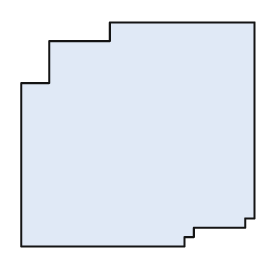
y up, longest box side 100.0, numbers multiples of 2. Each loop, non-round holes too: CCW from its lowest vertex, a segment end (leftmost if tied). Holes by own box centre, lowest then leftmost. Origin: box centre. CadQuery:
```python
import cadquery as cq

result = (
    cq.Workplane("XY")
    .moveTo(-50.0, -48.0)
    .lineTo(20.0, -48.0)
    .lineTo(20.0, -44.0)
    .lineTo(24.0, -44.0)
    .lineTo(24.0, -40.0)
    .lineTo(46.0, -40.0)
    .lineTo(46.0, -36.0)
    .lineTo(50.0, -36.0)
    .lineTo(50.0, 48.0)
    .lineTo(-12.0, 48.0)
    .lineTo(-12.0, 40.0)
    .lineTo(-38.0, 40.0)
    .lineTo(-38.0, 22.0)
    .lineTo(-50.0, 22.0)
    .close()
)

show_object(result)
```